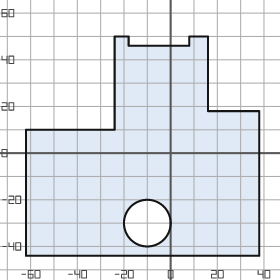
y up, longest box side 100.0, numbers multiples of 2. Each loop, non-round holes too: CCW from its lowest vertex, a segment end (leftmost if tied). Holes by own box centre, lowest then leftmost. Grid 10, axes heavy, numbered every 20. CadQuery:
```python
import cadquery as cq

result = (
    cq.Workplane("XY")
    .moveTo(-62.0, -44.0)
    .lineTo(38.0, -44.0)
    .lineTo(38.0, 18.0)
    .lineTo(16.0, 18.0)
    .lineTo(16.0, 50.0)
    .lineTo(8.0, 50.0)
    .lineTo(8.0, 46.0)
    .lineTo(-18.0, 46.0)
    .lineTo(-18.0, 50.0)
    .lineTo(-24.0, 50.0)
    .lineTo(-24.0, 10.0)
    .lineTo(-62.0, 10.0)
    .close()
    .moveTo(-10.0, -30.0)
    .circle(10.0)
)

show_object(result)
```